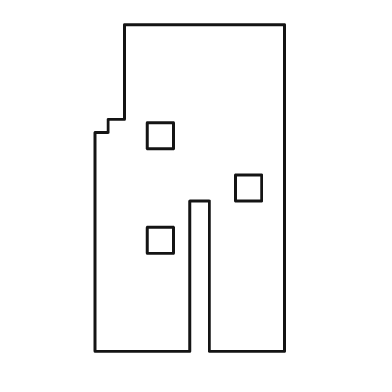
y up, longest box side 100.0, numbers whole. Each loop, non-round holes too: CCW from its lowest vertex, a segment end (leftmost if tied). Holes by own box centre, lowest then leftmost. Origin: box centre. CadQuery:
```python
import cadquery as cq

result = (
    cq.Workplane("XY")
    .moveTo(-29.0, -50.0)
    .lineTo(0.0, -50.0)
    .lineTo(0.0, -4.0)
    .lineTo(6.0, -4.0)
    .lineTo(6.0, -50.0)
    .lineTo(29.0, -50.0)
    .lineTo(29.0, 50.0)
    .lineTo(-20.0, 50.0)
    .lineTo(-20.0, 21.0)
    .lineTo(-25.0, 21.0)
    .lineTo(-25.0, 17.0)
    .lineTo(-29.0, 17.0)
    .close()
    .moveTo(-13.0, -20.0)
    .lineTo(-5.0, -20.0)
    .lineTo(-5.0, -12.0)
    .lineTo(-13.0, -12.0)
    .close()
    .moveTo(14.0, -4.0)
    .lineTo(22.0, -4.0)
    .lineTo(22.0, 4.0)
    .lineTo(14.0, 4.0)
    .close()
    .moveTo(-13.0, 12.0)
    .lineTo(-5.0, 12.0)
    .lineTo(-5.0, 20.0)
    .lineTo(-13.0, 20.0)
    .close()
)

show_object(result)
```